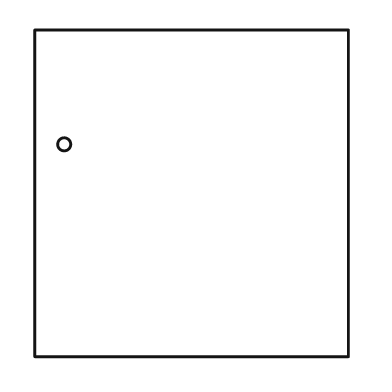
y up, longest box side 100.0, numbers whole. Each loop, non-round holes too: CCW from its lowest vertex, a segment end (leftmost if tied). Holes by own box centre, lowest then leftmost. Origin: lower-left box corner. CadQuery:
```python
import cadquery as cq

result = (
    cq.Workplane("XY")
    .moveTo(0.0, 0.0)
    .lineTo(96.0, 0.0)
    .lineTo(96.0, 100.0)
    .lineTo(0.0, 100.0)
    .close()
    .moveTo(9.0, 65.0)
    .circle(2.0)
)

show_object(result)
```